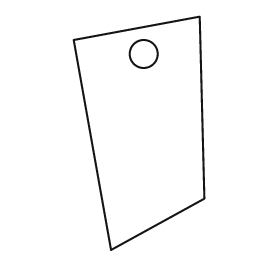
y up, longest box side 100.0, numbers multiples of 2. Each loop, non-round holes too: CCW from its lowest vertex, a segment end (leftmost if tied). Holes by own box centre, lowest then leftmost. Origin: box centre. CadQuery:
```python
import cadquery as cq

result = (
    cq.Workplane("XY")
    .moveTo(-12.0, -50.0)
    .lineTo(28.0, -28.0)
    .lineTo(26.0, 50.0)
    .lineTo(-28.0, 40.0)
    .close()
    .moveTo(2.0, 34.0)
    .circle(6.0)
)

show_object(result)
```